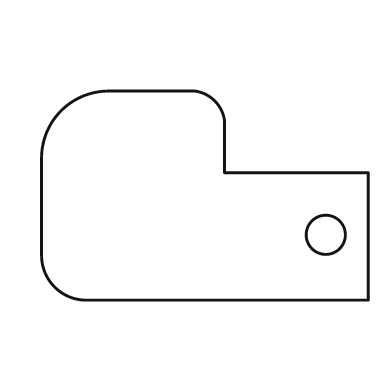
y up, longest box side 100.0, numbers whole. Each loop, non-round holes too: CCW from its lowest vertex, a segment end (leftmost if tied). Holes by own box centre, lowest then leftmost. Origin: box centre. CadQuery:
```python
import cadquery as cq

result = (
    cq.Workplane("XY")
    .moveTo(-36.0, -32.0)
    .lineTo(50.0, -32.0)
    .lineTo(50.0, 7.0)
    .lineTo(6.0, 7.0)
    .lineTo(6.0, 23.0)
    .threePointArc((3.0, 29.0), (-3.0, 32.0))
    .lineTo(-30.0, 32.0)
    .threePointArc((-44.0, 26.0), (-50.0, 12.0))
    .lineTo(-50.0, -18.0)
    .threePointArc((-46.0, -28.0), (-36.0, -32.0))
    .close()
    .moveTo(37.0, -12.0)
    .circle(6.0)
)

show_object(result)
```